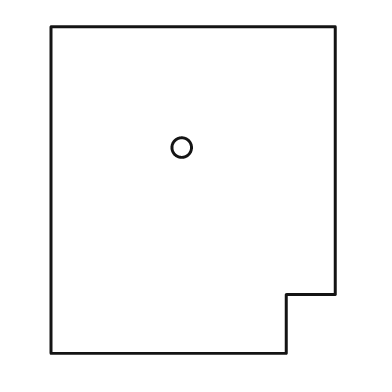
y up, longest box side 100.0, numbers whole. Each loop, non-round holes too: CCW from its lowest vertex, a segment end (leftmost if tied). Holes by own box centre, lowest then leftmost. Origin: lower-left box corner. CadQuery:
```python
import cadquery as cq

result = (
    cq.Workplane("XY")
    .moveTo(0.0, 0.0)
    .lineTo(72.0, 0.0)
    .lineTo(72.0, 18.0)
    .lineTo(87.0, 18.0)
    .lineTo(87.0, 100.0)
    .lineTo(0.0, 100.0)
    .close()
    .moveTo(40.0, 63.0)
    .circle(3.0)
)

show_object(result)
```